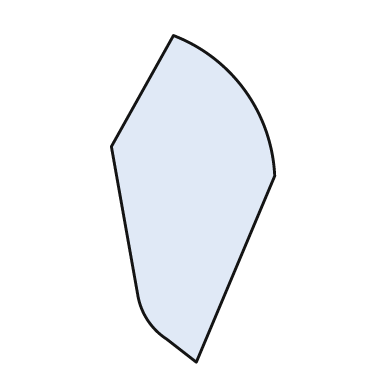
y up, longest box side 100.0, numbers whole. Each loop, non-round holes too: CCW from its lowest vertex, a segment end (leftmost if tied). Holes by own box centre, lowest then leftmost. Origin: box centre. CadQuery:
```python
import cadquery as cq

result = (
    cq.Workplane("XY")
    .moveTo(1.0, -50.0)
    .lineTo(25.0, 7.0)
    .threePointArc((16.0, 33.0), (-6.0, 50.0))
    .lineTo(-25.0, 16.0)
    .lineTo(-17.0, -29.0)
    .threePointArc((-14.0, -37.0), (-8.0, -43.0))
    .close()
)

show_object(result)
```